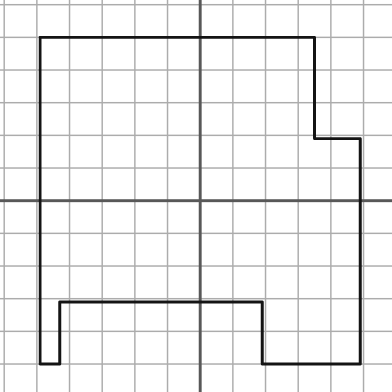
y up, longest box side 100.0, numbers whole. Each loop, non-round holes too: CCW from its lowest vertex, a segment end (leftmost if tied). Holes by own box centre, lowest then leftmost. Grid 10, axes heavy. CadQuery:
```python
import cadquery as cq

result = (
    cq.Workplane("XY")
    .moveTo(-49.0, -50.0)
    .lineTo(-43.0, -50.0)
    .lineTo(-43.0, -31.0)
    .lineTo(19.0, -31.0)
    .lineTo(19.0, -50.0)
    .lineTo(49.0, -50.0)
    .lineTo(49.0, 19.0)
    .lineTo(35.0, 19.0)
    .lineTo(35.0, 50.0)
    .lineTo(-49.0, 50.0)
    .close()
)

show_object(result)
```